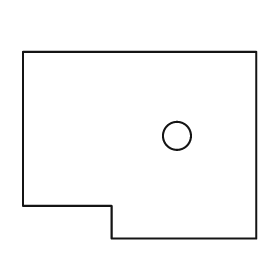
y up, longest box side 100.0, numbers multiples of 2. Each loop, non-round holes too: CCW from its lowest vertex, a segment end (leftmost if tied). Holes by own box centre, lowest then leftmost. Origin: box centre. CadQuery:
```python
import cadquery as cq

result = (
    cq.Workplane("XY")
    .moveTo(-12.0, -40.0)
    .lineTo(50.0, -40.0)
    .lineTo(50.0, 40.0)
    .lineTo(-50.0, 40.0)
    .lineTo(-50.0, -26.0)
    .lineTo(-12.0, -26.0)
    .close()
    .moveTo(16.0, 4.0)
    .circle(6.0)
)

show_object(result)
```